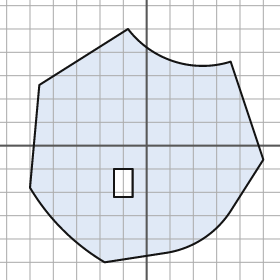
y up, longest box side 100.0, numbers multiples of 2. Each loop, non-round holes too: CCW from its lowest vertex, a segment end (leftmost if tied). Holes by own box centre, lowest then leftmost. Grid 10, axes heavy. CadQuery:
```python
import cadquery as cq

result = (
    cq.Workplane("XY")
    .moveTo(-18.0, -50.0)
    .lineTo(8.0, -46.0)
    .threePointArc((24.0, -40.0), (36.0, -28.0))
    .lineTo(50.0, -6.0)
    .lineTo(36.0, 36.0)
    .threePointArc((12.0, 36.0), (-8.0, 50.0))
    .lineTo(-46.0, 26.0)
    .lineTo(-50.0, -18.0)
    .threePointArc((-36.0, -36.0), (-18.0, -50.0))
    .close()
    .moveTo(-14.0, -22.0)
    .lineTo(-6.0, -22.0)
    .lineTo(-6.0, -10.0)
    .lineTo(-14.0, -10.0)
    .close()
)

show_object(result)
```